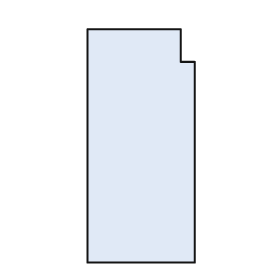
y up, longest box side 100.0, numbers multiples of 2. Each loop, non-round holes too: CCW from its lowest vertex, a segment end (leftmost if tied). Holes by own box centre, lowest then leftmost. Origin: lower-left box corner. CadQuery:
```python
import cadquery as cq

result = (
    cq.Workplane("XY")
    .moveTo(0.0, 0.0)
    .lineTo(46.0, 0.0)
    .lineTo(46.0, 86.0)
    .lineTo(40.0, 86.0)
    .lineTo(40.0, 100.0)
    .lineTo(0.0, 100.0)
    .close()
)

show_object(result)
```